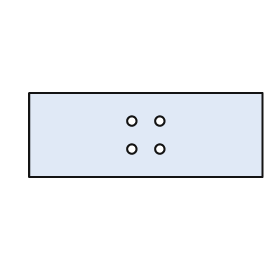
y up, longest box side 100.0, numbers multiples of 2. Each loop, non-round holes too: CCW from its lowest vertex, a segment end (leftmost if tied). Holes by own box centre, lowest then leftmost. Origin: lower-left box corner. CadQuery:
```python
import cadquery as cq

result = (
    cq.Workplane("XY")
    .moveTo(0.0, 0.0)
    .lineTo(100.0, 0.0)
    .lineTo(100.0, 36.0)
    .lineTo(0.0, 36.0)
    .close()
    .moveTo(44.0, 12.0)
    .circle(2.0)
    .moveTo(56.0, 12.0)
    .circle(2.0)
    .moveTo(44.0, 24.0)
    .circle(2.0)
    .moveTo(56.0, 24.0)
    .circle(2.0)
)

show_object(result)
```